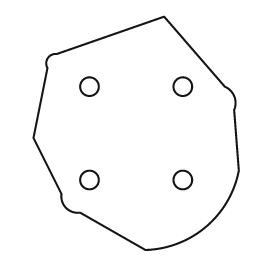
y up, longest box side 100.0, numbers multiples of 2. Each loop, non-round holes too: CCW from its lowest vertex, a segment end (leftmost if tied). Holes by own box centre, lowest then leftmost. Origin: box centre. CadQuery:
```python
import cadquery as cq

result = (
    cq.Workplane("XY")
    .moveTo(4.0, -50.0)
    .threePointArc((30.0, -40.0), (44.0, -16.0))
    .lineTo(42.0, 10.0)
    .threePointArc((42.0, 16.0), (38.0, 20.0))
    .lineTo(12.0, 50.0)
    .lineTo(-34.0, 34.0)
    .threePointArc((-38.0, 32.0), (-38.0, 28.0))
    .lineTo(-44.0, -2.0)
    .lineTo(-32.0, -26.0)
    .threePointArc((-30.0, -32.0), (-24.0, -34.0))
    .close()
    .moveTo(-20.0, -20.0)
    .circle(4.0)
    .moveTo(20.0, -20.0)
    .circle(4.0)
    .moveTo(-20.0, 20.0)
    .circle(4.0)
    .moveTo(20.0, 20.0)
    .circle(4.0)
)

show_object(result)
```